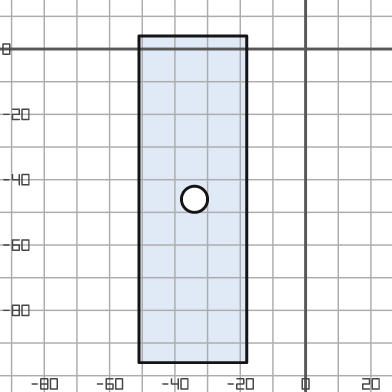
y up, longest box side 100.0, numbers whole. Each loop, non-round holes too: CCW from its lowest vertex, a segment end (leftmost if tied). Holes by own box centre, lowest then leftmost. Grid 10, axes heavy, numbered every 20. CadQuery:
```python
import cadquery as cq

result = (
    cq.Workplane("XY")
    .moveTo(-51.0, -96.0)
    .lineTo(-18.0, -96.0)
    .lineTo(-18.0, 4.0)
    .lineTo(-51.0, 4.0)
    .close()
    .moveTo(-34.0, -46.0)
    .circle(4.0)
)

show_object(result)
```